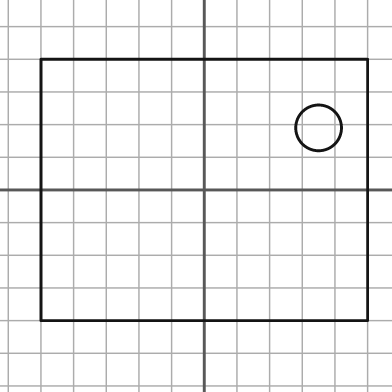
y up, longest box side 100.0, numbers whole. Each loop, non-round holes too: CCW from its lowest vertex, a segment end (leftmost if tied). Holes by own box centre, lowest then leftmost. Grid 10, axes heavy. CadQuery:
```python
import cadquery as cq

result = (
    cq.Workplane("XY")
    .moveTo(-50.0, -40.0)
    .lineTo(50.0, -40.0)
    .lineTo(50.0, 40.0)
    .lineTo(-50.0, 40.0)
    .close()
    .moveTo(35.0, 19.0)
    .circle(7.0)
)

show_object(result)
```